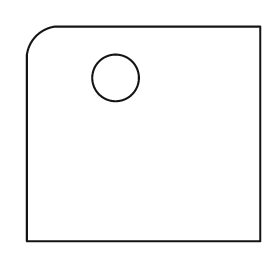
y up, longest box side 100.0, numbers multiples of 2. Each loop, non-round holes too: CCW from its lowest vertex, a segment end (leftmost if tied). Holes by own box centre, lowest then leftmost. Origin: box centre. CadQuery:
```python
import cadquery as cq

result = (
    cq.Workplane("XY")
    .moveTo(-50.0, -46.0)
    .lineTo(50.0, -46.0)
    .lineTo(50.0, 46.0)
    .lineTo(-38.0, 46.0)
    .threePointArc((-46.0, 42.0), (-50.0, 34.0))
    .close()
    .moveTo(-12.0, 24.0)
    .circle(10.0)
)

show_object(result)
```